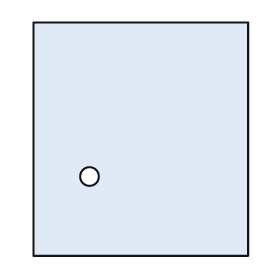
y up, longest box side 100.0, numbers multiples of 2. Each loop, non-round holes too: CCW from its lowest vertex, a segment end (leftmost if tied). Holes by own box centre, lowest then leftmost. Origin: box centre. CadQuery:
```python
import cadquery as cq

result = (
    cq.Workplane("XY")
    .moveTo(-46.0, -50.0)
    .lineTo(46.0, -50.0)
    .lineTo(46.0, 50.0)
    .lineTo(-46.0, 50.0)
    .close()
    .moveTo(-22.0, -16.0)
    .circle(4.0)
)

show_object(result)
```